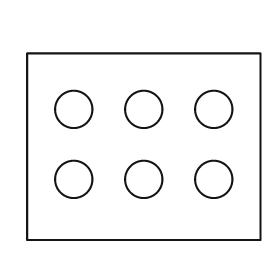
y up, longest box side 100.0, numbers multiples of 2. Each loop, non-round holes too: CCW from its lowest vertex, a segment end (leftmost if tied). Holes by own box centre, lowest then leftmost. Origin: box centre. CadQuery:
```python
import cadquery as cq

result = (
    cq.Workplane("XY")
    .moveTo(-50.0, -40.0)
    .lineTo(50.0, -40.0)
    .lineTo(50.0, 40.0)
    .lineTo(-50.0, 40.0)
    .close()
    .moveTo(-30.0, -14.0)
    .circle(8.0)
    .moveTo(0.0, -14.0)
    .circle(8.0)
    .moveTo(30.0, -14.0)
    .circle(8.0)
    .moveTo(-30.0, 16.0)
    .circle(8.0)
    .moveTo(0.0, 16.0)
    .circle(8.0)
    .moveTo(30.0, 16.0)
    .circle(8.0)
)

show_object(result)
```